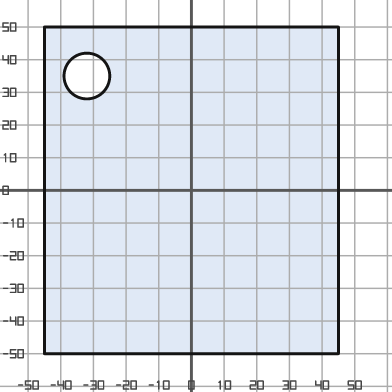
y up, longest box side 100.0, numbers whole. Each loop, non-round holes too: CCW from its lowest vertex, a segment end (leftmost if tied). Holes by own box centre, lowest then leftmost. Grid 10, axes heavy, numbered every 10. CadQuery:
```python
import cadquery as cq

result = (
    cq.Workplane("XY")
    .moveTo(-45.0, -50.0)
    .lineTo(45.0, -50.0)
    .lineTo(45.0, 50.0)
    .lineTo(-45.0, 50.0)
    .close()
    .moveTo(-32.0, 35.0)
    .circle(7.0)
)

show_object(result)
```